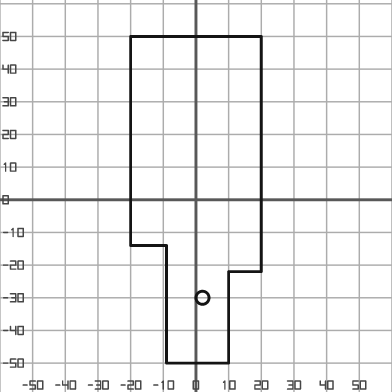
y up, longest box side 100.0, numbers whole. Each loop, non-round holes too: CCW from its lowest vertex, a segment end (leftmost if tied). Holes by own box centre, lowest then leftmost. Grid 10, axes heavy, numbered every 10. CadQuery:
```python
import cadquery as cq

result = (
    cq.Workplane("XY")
    .moveTo(-9.0, -50.0)
    .lineTo(10.0, -50.0)
    .lineTo(10.0, -22.0)
    .lineTo(20.0, -22.0)
    .lineTo(20.0, 50.0)
    .lineTo(-20.0, 50.0)
    .lineTo(-20.0, -14.0)
    .lineTo(-9.0, -14.0)
    .close()
    .moveTo(2.0, -30.0)
    .circle(2.0)
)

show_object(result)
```